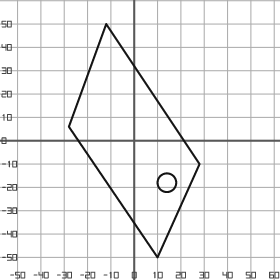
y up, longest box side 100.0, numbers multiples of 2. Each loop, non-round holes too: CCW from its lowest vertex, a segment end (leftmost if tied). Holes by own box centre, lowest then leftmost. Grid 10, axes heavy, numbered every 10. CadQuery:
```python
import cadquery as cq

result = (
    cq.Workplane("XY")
    .moveTo(10.0, -50.0)
    .lineTo(28.0, -10.0)
    .lineTo(-12.0, 50.0)
    .lineTo(-28.0, 6.0)
    .close()
    .moveTo(14.0, -18.0)
    .circle(4.0)
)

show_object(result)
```